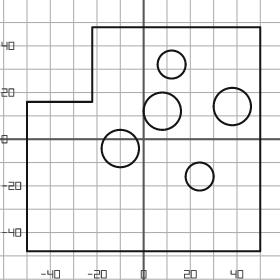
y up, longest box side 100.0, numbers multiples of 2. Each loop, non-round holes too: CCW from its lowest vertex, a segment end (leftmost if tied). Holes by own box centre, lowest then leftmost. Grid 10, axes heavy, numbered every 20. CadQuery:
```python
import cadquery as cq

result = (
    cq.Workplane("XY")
    .moveTo(-50.0, -48.0)
    .lineTo(50.0, -48.0)
    .lineTo(50.0, 48.0)
    .lineTo(-22.0, 48.0)
    .lineTo(-22.0, 16.0)
    .lineTo(-50.0, 16.0)
    .close()
    .moveTo(24.0, -16.0)
    .circle(6.0)
    .moveTo(-10.0, -4.0)
    .circle(8.0)
    .moveTo(8.0, 12.0)
    .circle(8.0)
    .moveTo(38.0, 14.0)
    .circle(8.0)
    .moveTo(12.0, 32.0)
    .circle(6.0)
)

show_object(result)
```